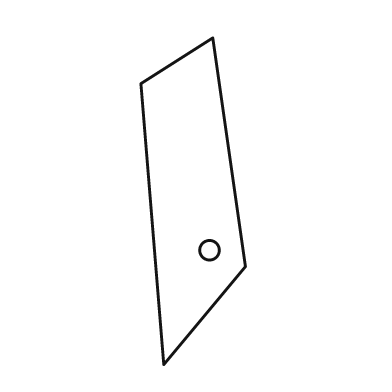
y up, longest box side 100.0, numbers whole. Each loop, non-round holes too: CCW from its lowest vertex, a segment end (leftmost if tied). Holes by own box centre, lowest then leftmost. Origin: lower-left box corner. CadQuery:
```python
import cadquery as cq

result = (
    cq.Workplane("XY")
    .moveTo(7.0, 0.0)
    .lineTo(32.0, 30.0)
    .lineTo(22.0, 100.0)
    .lineTo(0.0, 86.0)
    .close()
    .moveTo(21.0, 35.0)
    .circle(3.0)
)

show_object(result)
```